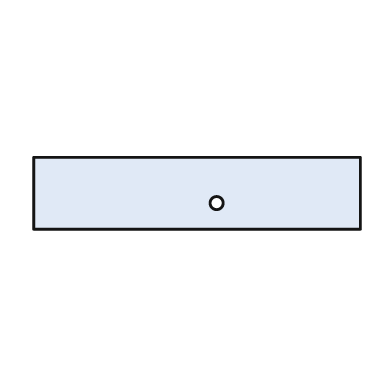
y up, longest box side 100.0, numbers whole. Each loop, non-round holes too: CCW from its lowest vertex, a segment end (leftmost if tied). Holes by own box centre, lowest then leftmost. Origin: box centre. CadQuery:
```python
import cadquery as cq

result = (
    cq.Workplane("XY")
    .moveTo(-50.0, -11.0)
    .lineTo(50.0, -11.0)
    .lineTo(50.0, 11.0)
    .lineTo(-50.0, 11.0)
    .close()
    .moveTo(6.0, -3.0)
    .circle(2.0)
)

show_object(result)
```